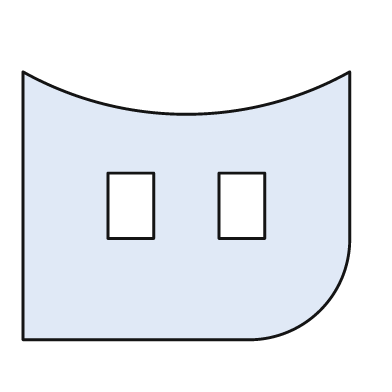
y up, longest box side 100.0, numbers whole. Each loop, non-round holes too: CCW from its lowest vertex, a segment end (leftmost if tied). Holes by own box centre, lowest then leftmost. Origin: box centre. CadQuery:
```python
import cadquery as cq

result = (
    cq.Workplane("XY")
    .moveTo(-50.0, -41.0)
    .lineTo(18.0, -41.0)
    .threePointArc((41.0, -32.0), (50.0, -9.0))
    .lineTo(50.0, 41.0)
    .threePointArc((0.0, 28.0), (-50.0, 41.0))
    .close()
    .moveTo(-24.0, -10.0)
    .lineTo(-10.0, -10.0)
    .lineTo(-10.0, 10.0)
    .lineTo(-24.0, 10.0)
    .close()
    .moveTo(10.0, -10.0)
    .lineTo(24.0, -10.0)
    .lineTo(24.0, 10.0)
    .lineTo(10.0, 10.0)
    .close()
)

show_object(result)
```